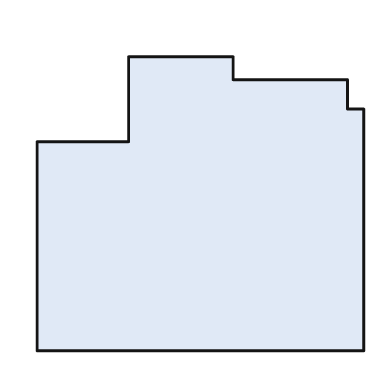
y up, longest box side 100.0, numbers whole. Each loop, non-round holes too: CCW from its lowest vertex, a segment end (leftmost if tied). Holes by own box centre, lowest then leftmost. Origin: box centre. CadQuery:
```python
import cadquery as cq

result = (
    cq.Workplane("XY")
    .moveTo(-50.0, -45.0)
    .lineTo(50.0, -45.0)
    .lineTo(50.0, 29.0)
    .lineTo(45.0, 29.0)
    .lineTo(45.0, 38.0)
    .lineTo(10.0, 38.0)
    .lineTo(10.0, 45.0)
    .lineTo(-22.0, 45.0)
    .lineTo(-22.0, 19.0)
    .lineTo(-50.0, 19.0)
    .close()
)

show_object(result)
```